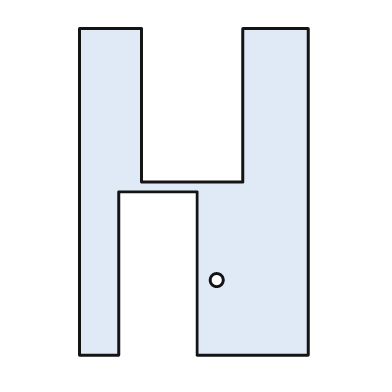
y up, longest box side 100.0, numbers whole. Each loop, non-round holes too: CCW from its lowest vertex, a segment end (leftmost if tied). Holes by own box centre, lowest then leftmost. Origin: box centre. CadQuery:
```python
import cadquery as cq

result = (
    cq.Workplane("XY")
    .moveTo(-35.0, -50.0)
    .lineTo(-23.0, -50.0)
    .lineTo(-23.0, 0.0)
    .lineTo(1.0, 0.0)
    .lineTo(1.0, -50.0)
    .lineTo(35.0, -50.0)
    .lineTo(35.0, 50.0)
    .lineTo(15.0, 50.0)
    .lineTo(15.0, 3.0)
    .lineTo(-16.0, 3.0)
    .lineTo(-16.0, 50.0)
    .lineTo(-35.0, 50.0)
    .close()
    .moveTo(7.0, -27.0)
    .circle(2.0)
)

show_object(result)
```